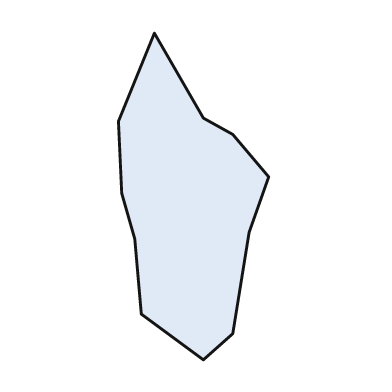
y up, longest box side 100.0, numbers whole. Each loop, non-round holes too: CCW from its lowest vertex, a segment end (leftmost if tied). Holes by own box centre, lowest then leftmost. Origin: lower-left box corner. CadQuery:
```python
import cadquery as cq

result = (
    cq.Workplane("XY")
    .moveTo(26.0, 0.0)
    .lineTo(35.0, 8.0)
    .lineTo(40.0, 39.0)
    .lineTo(46.0, 56.0)
    .lineTo(35.0, 69.0)
    .lineTo(26.0, 74.0)
    .lineTo(11.0, 100.0)
    .lineTo(0.0, 73.0)
    .lineTo(1.0, 51.0)
    .lineTo(5.0, 37.0)
    .lineTo(7.0, 14.0)
    .close()
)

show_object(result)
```